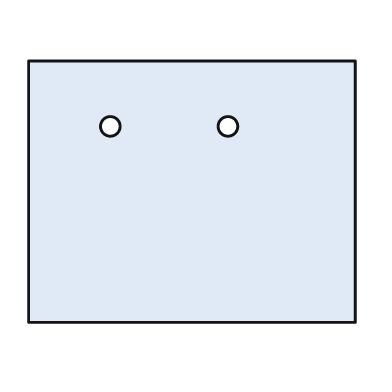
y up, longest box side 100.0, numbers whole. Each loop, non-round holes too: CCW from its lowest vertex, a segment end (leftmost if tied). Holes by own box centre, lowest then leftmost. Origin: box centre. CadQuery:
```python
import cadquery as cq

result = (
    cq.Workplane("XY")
    .moveTo(-50.0, -40.0)
    .lineTo(50.0, -40.0)
    .lineTo(50.0, 40.0)
    .lineTo(-50.0, 40.0)
    .close()
    .moveTo(-25.0, 20.0)
    .circle(3.0)
    .moveTo(11.0, 20.0)
    .circle(3.0)
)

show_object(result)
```